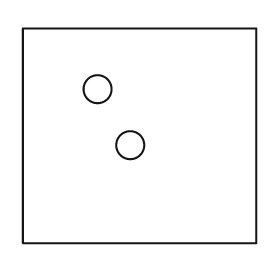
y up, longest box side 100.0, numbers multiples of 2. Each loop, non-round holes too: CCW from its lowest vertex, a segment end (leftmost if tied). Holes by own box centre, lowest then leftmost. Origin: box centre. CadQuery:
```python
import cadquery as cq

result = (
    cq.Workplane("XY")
    .moveTo(-50.0, -46.0)
    .lineTo(50.0, -46.0)
    .lineTo(50.0, 46.0)
    .lineTo(-50.0, 46.0)
    .close()
    .moveTo(-4.0, -4.0)
    .circle(6.0)
    .moveTo(-18.0, 20.0)
    .circle(6.0)
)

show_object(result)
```